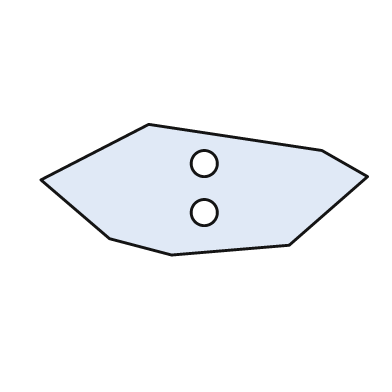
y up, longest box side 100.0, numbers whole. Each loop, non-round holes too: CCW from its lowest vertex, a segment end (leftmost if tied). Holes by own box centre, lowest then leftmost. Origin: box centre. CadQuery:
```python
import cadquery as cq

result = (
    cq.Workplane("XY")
    .moveTo(-10.0, -20.0)
    .lineTo(26.0, -17.0)
    .lineTo(50.0, 4.0)
    .lineTo(36.0, 12.0)
    .lineTo(-17.0, 20.0)
    .lineTo(-50.0, 3.0)
    .lineTo(-29.0, -15.0)
    .close()
    .moveTo(0.0, -7.0)
    .circle(4.0)
    .moveTo(0.0, 8.0)
    .circle(4.0)
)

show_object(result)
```